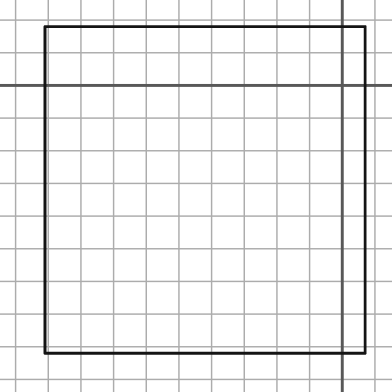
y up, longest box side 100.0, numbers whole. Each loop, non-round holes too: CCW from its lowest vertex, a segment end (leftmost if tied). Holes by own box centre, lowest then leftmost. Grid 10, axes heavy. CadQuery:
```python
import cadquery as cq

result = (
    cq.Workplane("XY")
    .moveTo(-91.0, -82.0)
    .lineTo(7.0, -82.0)
    .lineTo(7.0, 18.0)
    .lineTo(-91.0, 18.0)
    .close()
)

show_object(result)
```